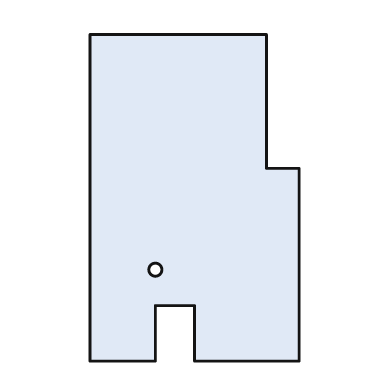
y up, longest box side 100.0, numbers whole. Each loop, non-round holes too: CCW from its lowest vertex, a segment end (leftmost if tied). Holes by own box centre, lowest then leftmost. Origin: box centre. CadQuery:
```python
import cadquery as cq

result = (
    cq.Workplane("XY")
    .moveTo(-32.0, -50.0)
    .lineTo(-12.0, -50.0)
    .lineTo(-12.0, -33.0)
    .lineTo(0.0, -33.0)
    .lineTo(0.0, -50.0)
    .lineTo(32.0, -50.0)
    .lineTo(32.0, 9.0)
    .lineTo(22.0, 9.0)
    .lineTo(22.0, 50.0)
    .lineTo(-32.0, 50.0)
    .close()
    .moveTo(-12.0, -22.0)
    .circle(2.0)
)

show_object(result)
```